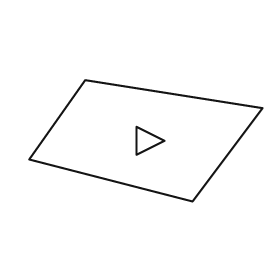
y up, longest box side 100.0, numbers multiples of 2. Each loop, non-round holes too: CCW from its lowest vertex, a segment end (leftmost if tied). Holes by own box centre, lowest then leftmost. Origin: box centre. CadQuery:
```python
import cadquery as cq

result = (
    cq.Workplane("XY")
    .moveTo(20.0, -26.0)
    .lineTo(50.0, 14.0)
    .lineTo(-26.0, 26.0)
    .lineTo(-50.0, -8.0)
    .close()
    .moveTo(-4.0, -6.0)
    .lineTo(8.0, 0.0)
    .lineTo(-4.0, 6.0)
    .close()
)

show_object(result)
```